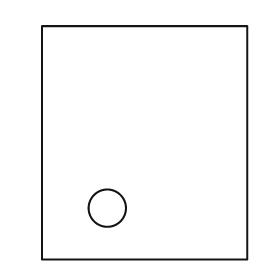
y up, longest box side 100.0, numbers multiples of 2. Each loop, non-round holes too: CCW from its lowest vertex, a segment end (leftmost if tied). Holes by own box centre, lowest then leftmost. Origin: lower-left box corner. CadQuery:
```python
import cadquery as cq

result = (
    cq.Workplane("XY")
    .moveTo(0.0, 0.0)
    .lineTo(88.0, 0.0)
    .lineTo(88.0, 100.0)
    .lineTo(0.0, 100.0)
    .close()
    .moveTo(28.0, 22.0)
    .circle(8.0)
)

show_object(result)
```